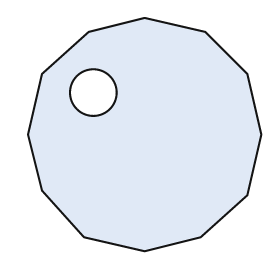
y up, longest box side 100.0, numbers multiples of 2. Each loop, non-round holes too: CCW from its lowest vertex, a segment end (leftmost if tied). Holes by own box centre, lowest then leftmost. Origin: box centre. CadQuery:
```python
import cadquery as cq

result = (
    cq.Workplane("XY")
    .moveTo(0.0, -50.0)
    .lineTo(24.0, -44.0)
    .lineTo(44.0, -26.0)
    .lineTo(50.0, 0.0)
    .lineTo(44.0, 26.0)
    .lineTo(26.0, 44.0)
    .lineTo(0.0, 50.0)
    .lineTo(-24.0, 44.0)
    .lineTo(-44.0, 26.0)
    .lineTo(-50.0, 0.0)
    .lineTo(-44.0, -24.0)
    .lineTo(-26.0, -44.0)
    .close()
    .moveTo(-22.0, 18.0)
    .circle(10.0)
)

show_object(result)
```